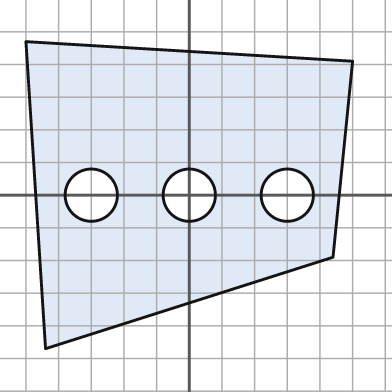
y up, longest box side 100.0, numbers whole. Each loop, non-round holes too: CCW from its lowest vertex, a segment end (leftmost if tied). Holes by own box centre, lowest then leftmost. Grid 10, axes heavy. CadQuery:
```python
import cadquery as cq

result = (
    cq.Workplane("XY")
    .moveTo(-44.0, -47.0)
    .lineTo(44.0, -19.0)
    .lineTo(50.0, 41.0)
    .lineTo(-50.0, 47.0)
    .close()
    .moveTo(-30.0, 0.0)
    .circle(8.0)
    .moveTo(0.0, 0.0)
    .circle(8.0)
    .moveTo(30.0, 0.0)
    .circle(8.0)
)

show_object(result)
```